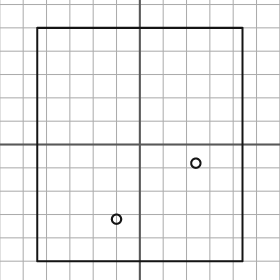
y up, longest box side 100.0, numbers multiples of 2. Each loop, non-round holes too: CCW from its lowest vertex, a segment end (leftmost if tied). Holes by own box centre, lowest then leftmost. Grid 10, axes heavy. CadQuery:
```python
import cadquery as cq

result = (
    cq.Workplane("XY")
    .moveTo(-44.0, -50.0)
    .lineTo(44.0, -50.0)
    .lineTo(44.0, 50.0)
    .lineTo(-44.0, 50.0)
    .close()
    .moveTo(-10.0, -32.0)
    .circle(2.0)
    .moveTo(24.0, -8.0)
    .circle(2.0)
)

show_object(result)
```